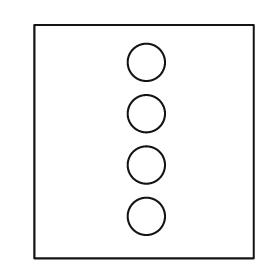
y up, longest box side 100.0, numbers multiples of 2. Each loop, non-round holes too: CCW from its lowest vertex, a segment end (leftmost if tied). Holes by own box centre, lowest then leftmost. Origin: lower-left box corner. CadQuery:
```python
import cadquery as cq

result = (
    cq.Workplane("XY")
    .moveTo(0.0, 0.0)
    .lineTo(94.0, 0.0)
    .lineTo(94.0, 100.0)
    .lineTo(0.0, 100.0)
    .close()
    .moveTo(48.0, 18.0)
    .circle(8.0)
    .moveTo(48.0, 40.0)
    .circle(8.0)
    .moveTo(48.0, 62.0)
    .circle(8.0)
    .moveTo(48.0, 84.0)
    .circle(8.0)
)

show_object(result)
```